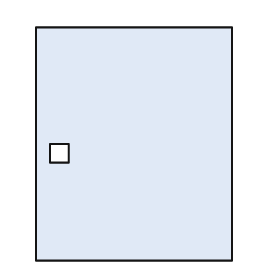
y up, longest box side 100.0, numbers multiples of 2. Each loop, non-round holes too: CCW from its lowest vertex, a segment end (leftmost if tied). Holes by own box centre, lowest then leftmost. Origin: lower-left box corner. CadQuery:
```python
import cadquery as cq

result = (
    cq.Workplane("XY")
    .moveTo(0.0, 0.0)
    .lineTo(84.0, 0.0)
    .lineTo(84.0, 100.0)
    .lineTo(0.0, 100.0)
    .close()
    .moveTo(6.0, 42.0)
    .lineTo(14.0, 42.0)
    .lineTo(14.0, 50.0)
    .lineTo(6.0, 50.0)
    .close()
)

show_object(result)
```